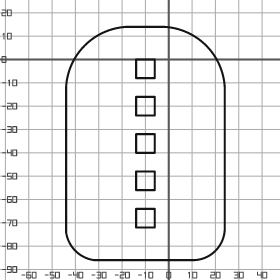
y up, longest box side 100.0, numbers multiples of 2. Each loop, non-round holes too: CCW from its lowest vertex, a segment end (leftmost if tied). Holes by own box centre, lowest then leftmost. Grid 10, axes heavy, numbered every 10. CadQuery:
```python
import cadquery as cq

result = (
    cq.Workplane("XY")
    .moveTo(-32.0, -86.0)
    .lineTo(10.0, -86.0)
    .threePointArc((20.0, -82.0), (24.0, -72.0))
    .lineTo(24.0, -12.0)
    .threePointArc((16.0, 6.0), (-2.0, 14.0))
    .lineTo(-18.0, 14.0)
    .threePointArc((-36.0, 6.0), (-44.0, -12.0))
    .lineTo(-44.0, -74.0)
    .threePointArc((-40.0, -82.0), (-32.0, -86.0))
    .close()
    .moveTo(-14.0, -72.0)
    .lineTo(-6.0, -72.0)
    .lineTo(-6.0, -64.0)
    .lineTo(-14.0, -64.0)
    .close()
    .moveTo(-14.0, -56.0)
    .lineTo(-6.0, -56.0)
    .lineTo(-6.0, -48.0)
    .lineTo(-14.0, -48.0)
    .close()
    .moveTo(-14.0, -40.0)
    .lineTo(-6.0, -40.0)
    .lineTo(-6.0, -32.0)
    .lineTo(-14.0, -32.0)
    .close()
    .moveTo(-14.0, -24.0)
    .lineTo(-6.0, -24.0)
    .lineTo(-6.0, -16.0)
    .lineTo(-14.0, -16.0)
    .close()
    .moveTo(-14.0, -8.0)
    .lineTo(-6.0, -8.0)
    .lineTo(-6.0, 0.0)
    .lineTo(-14.0, 0.0)
    .close()
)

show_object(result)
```